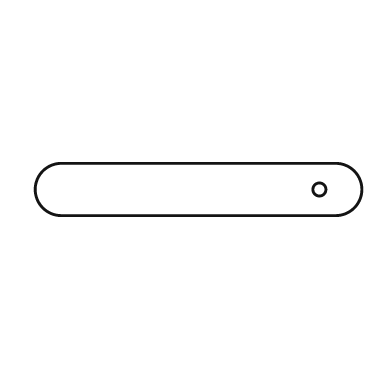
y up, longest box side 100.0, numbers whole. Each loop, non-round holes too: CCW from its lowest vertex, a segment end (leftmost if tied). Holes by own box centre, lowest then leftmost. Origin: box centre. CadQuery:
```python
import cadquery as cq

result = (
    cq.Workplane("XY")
    .moveTo(-42.0, -8.0)
    .lineTo(42.0, -8.0)
    .threePointArc((50.0, 0.0), (42.0, 8.0))
    .lineTo(-42.0, 8.0)
    .threePointArc((-50.0, 0.0), (-42.0, -8.0))
    .close()
    .moveTo(37.0, 0.0)
    .circle(2.0)
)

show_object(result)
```